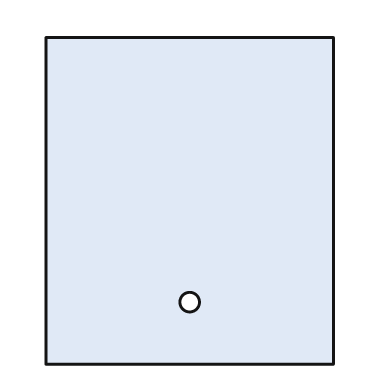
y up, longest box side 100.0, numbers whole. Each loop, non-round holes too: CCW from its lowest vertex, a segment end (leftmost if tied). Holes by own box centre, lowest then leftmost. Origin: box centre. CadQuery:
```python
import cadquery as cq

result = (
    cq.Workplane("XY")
    .moveTo(-44.0, -50.0)
    .lineTo(44.0, -50.0)
    .lineTo(44.0, 50.0)
    .lineTo(-44.0, 50.0)
    .close()
    .moveTo(0.0, -31.0)
    .circle(3.0)
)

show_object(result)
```